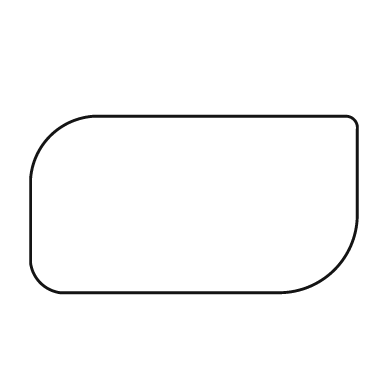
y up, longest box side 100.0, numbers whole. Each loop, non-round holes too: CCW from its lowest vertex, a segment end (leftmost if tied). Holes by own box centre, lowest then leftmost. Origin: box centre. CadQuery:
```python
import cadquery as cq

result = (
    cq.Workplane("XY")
    .moveTo(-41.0, -27.0)
    .lineTo(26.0, -27.0)
    .threePointArc((43.0, -20.0), (50.0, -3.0))
    .lineTo(50.0, 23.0)
    .threePointArc((49.0, 26.0), (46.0, 27.0))
    .lineTo(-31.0, 27.0)
    .threePointArc((-44.0, 21.0), (-50.0, 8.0))
    .lineTo(-50.0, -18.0)
    .threePointArc((-47.0, -24.0), (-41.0, -27.0))
    .close()
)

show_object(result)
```